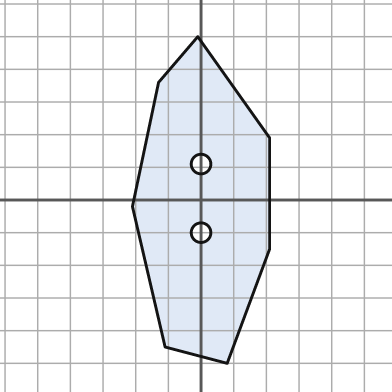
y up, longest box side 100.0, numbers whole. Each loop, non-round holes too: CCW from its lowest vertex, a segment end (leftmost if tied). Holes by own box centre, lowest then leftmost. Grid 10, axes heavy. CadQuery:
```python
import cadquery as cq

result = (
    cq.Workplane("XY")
    .moveTo(8.0, -50.0)
    .lineTo(21.0, -15.0)
    .lineTo(21.0, 19.0)
    .lineTo(-1.0, 50.0)
    .lineTo(-13.0, 36.0)
    .lineTo(-21.0, -2.0)
    .lineTo(-11.0, -45.0)
    .close()
    .moveTo(0.0, -10.0)
    .circle(3.0)
    .moveTo(0.0, 11.0)
    .circle(3.0)
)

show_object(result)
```